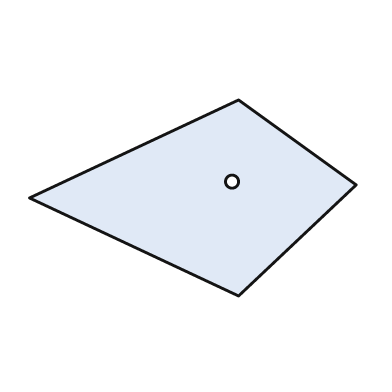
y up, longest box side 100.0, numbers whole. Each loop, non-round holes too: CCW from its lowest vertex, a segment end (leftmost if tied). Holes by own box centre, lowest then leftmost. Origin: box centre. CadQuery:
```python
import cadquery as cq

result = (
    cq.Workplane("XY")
    .moveTo(14.0, -30.0)
    .lineTo(50.0, 4.0)
    .lineTo(14.0, 30.0)
    .lineTo(-50.0, 0.0)
    .close()
    .moveTo(12.0, 5.0)
    .circle(2.0)
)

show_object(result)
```